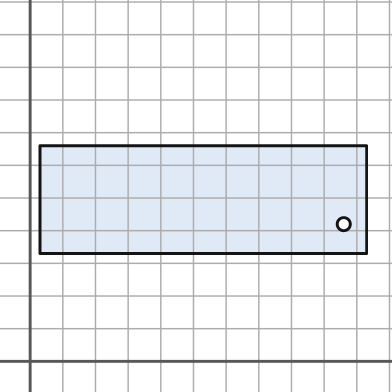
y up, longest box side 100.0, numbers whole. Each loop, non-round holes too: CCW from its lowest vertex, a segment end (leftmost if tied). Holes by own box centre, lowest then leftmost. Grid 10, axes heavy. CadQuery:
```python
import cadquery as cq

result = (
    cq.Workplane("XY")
    .moveTo(3.0, 33.0)
    .lineTo(103.0, 33.0)
    .lineTo(103.0, 66.0)
    .lineTo(3.0, 66.0)
    .close()
    .moveTo(96.0, 42.0)
    .circle(2.0)
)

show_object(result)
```